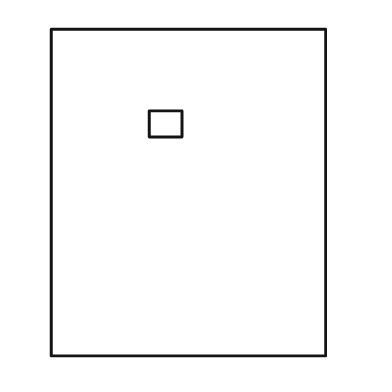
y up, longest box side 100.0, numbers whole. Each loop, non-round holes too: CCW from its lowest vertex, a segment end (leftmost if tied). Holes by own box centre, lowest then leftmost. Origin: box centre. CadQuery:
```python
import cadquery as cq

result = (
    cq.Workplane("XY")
    .moveTo(-42.0, -50.0)
    .lineTo(42.0, -50.0)
    .lineTo(42.0, 50.0)
    .lineTo(-42.0, 50.0)
    .close()
    .moveTo(-12.0, 17.0)
    .lineTo(-2.0, 17.0)
    .lineTo(-2.0, 25.0)
    .lineTo(-12.0, 25.0)
    .close()
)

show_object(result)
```